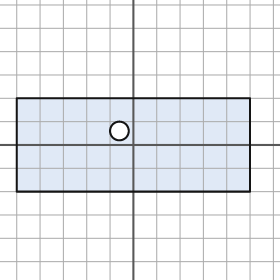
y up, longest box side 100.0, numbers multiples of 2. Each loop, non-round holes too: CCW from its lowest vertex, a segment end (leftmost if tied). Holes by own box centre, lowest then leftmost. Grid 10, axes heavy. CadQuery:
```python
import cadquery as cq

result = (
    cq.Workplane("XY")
    .moveTo(-50.0, -20.0)
    .lineTo(50.0, -20.0)
    .lineTo(50.0, 20.0)
    .lineTo(-50.0, 20.0)
    .close()
    .moveTo(-6.0, 6.0)
    .circle(4.0)
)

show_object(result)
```